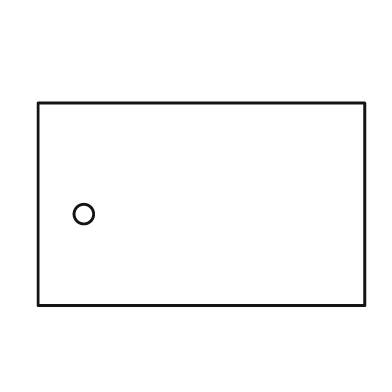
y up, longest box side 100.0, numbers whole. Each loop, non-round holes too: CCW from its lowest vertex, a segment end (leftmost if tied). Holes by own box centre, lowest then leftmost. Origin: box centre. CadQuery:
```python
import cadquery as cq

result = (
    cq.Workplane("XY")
    .moveTo(-50.0, -31.0)
    .lineTo(50.0, -31.0)
    .lineTo(50.0, 31.0)
    .lineTo(-50.0, 31.0)
    .close()
    .moveTo(-36.0, -3.0)
    .circle(3.0)
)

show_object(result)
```